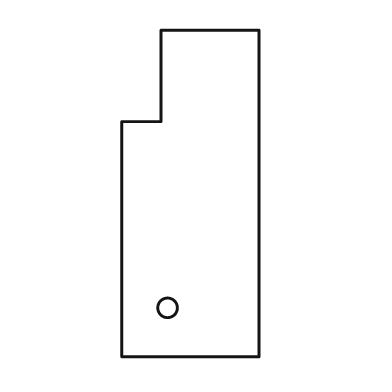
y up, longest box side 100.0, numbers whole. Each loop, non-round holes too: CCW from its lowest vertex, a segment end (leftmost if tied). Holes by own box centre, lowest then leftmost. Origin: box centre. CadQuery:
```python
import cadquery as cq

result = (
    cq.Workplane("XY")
    .moveTo(-21.0, -50.0)
    .lineTo(21.0, -50.0)
    .lineTo(21.0, 50.0)
    .lineTo(-9.0, 50.0)
    .lineTo(-9.0, 22.0)
    .lineTo(-21.0, 22.0)
    .close()
    .moveTo(-7.0, -35.0)
    .circle(3.0)
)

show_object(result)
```